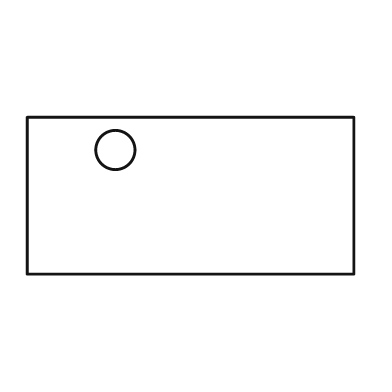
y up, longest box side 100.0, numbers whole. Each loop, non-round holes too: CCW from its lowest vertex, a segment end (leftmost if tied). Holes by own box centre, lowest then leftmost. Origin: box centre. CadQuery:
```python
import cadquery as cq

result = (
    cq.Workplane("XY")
    .moveTo(-50.0, -24.0)
    .lineTo(50.0, -24.0)
    .lineTo(50.0, 24.0)
    .lineTo(-50.0, 24.0)
    .close()
    .moveTo(-23.0, 14.0)
    .circle(6.0)
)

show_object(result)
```